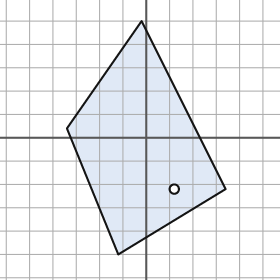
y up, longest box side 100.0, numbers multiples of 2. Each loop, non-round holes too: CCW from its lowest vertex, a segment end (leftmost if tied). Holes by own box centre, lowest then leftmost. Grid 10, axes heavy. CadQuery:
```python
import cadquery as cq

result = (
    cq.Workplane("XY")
    .moveTo(-12.0, -50.0)
    .lineTo(34.0, -22.0)
    .lineTo(-2.0, 50.0)
    .lineTo(-34.0, 4.0)
    .close()
    .moveTo(12.0, -22.0)
    .circle(2.0)
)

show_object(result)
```